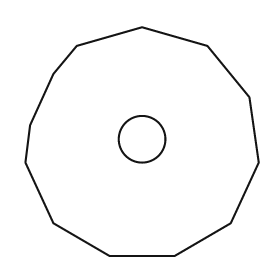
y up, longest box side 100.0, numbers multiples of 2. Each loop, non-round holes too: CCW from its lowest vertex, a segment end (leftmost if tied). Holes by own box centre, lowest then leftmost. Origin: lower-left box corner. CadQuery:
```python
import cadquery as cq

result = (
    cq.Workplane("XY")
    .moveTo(36.0, 0.0)
    .lineTo(64.0, 0.0)
    .lineTo(88.0, 14.0)
    .lineTo(100.0, 40.0)
    .lineTo(96.0, 68.0)
    .lineTo(78.0, 90.0)
    .lineTo(50.0, 98.0)
    .lineTo(22.0, 90.0)
    .lineTo(12.0, 78.0)
    .lineTo(2.0, 56.0)
    .lineTo(0.0, 40.0)
    .lineTo(12.0, 14.0)
    .close()
    .moveTo(50.0, 50.0)
    .circle(10.0)
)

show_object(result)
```